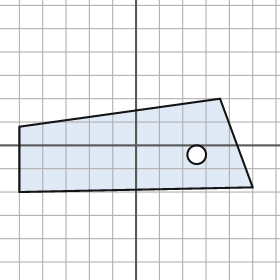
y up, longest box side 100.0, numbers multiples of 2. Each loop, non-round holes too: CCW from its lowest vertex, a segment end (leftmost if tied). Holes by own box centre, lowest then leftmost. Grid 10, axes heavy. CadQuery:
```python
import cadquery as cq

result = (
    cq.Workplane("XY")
    .moveTo(-50.0, -20.0)
    .lineTo(50.0, -18.0)
    .lineTo(36.0, 20.0)
    .lineTo(-50.0, 8.0)
    .close()
    .moveTo(26.0, -4.0)
    .circle(4.0)
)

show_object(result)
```